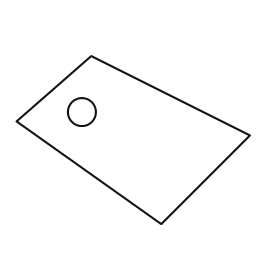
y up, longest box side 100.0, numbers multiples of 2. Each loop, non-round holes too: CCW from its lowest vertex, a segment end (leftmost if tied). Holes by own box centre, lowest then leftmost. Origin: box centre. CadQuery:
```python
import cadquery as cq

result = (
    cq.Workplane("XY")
    .moveTo(12.0, -36.0)
    .lineTo(50.0, 2.0)
    .lineTo(-18.0, 36.0)
    .lineTo(-50.0, 8.0)
    .close()
    .moveTo(-22.0, 12.0)
    .circle(6.0)
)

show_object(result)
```